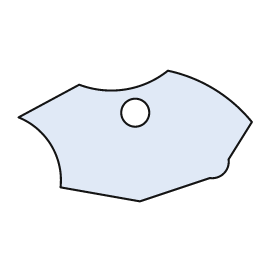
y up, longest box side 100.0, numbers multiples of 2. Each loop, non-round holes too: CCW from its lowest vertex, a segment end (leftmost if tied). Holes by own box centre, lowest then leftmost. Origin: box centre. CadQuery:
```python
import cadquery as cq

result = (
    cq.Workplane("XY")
    .moveTo(2.0, -28.0)
    .lineTo(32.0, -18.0)
    .threePointArc((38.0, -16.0), (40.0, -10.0))
    .lineTo(50.0, 6.0)
    .threePointArc((34.0, 20.0), (14.0, 28.0))
    .threePointArc((-4.0, 20.0), (-24.0, 22.0))
    .lineTo(-50.0, 8.0)
    .threePointArc((-36.0, -4.0), (-32.0, -22.0))
    .close()
    .moveTo(0.0, 10.0)
    .circle(6.0)
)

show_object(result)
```